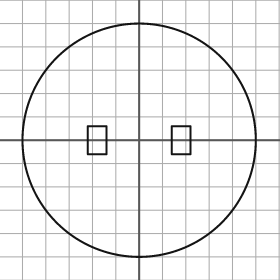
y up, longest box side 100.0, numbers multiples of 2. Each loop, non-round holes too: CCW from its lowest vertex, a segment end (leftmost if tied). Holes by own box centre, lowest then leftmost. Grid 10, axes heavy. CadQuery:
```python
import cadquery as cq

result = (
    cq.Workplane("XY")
    .moveTo(0.0, 0.0)
    .circle(50.0)
    .moveTo(-22.0, -6.0)
    .lineTo(-14.0, -6.0)
    .lineTo(-14.0, 6.0)
    .lineTo(-22.0, 6.0)
    .close()
    .moveTo(14.0, -6.0)
    .lineTo(22.0, -6.0)
    .lineTo(22.0, 6.0)
    .lineTo(14.0, 6.0)
    .close()
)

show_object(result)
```